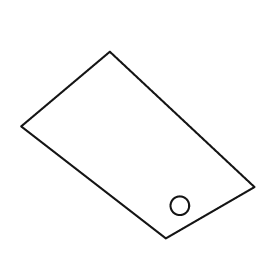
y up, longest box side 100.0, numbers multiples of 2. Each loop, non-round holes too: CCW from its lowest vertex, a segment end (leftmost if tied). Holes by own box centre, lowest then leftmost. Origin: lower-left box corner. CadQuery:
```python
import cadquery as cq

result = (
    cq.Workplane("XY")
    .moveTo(62.0, 0.0)
    .lineTo(100.0, 22.0)
    .lineTo(38.0, 80.0)
    .lineTo(0.0, 48.0)
    .close()
    .moveTo(68.0, 14.0)
    .circle(4.0)
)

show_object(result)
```